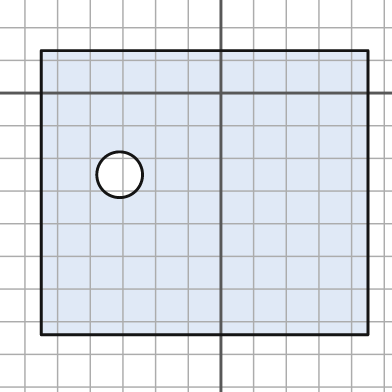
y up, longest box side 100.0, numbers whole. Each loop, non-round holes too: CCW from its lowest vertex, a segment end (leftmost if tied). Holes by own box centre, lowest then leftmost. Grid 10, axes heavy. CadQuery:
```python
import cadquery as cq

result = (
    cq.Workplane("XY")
    .moveTo(-55.0, -74.0)
    .lineTo(45.0, -74.0)
    .lineTo(45.0, 13.0)
    .lineTo(-55.0, 13.0)
    .close()
    .moveTo(-31.0, -25.0)
    .circle(7.0)
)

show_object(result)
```